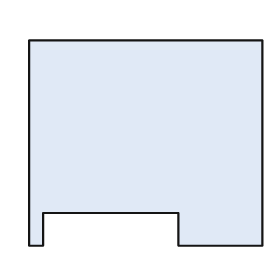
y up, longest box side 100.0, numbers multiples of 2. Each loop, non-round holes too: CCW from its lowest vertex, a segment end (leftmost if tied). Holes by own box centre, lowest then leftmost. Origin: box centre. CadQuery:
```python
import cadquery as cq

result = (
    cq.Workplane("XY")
    .moveTo(-50.0, -44.0)
    .lineTo(-44.0, -44.0)
    .lineTo(-44.0, -30.0)
    .lineTo(14.0, -30.0)
    .lineTo(14.0, -44.0)
    .lineTo(50.0, -44.0)
    .lineTo(50.0, 44.0)
    .lineTo(-50.0, 44.0)
    .close()
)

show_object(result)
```